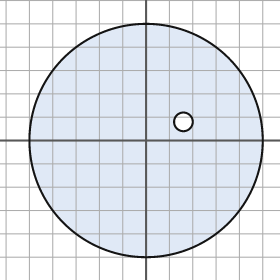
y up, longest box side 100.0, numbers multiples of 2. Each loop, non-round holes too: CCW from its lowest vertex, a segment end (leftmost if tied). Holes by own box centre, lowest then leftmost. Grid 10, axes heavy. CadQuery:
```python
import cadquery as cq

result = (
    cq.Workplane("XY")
    .moveTo(0.0, 0.0)
    .circle(50.0)
    .moveTo(16.0, 8.0)
    .circle(4.0)
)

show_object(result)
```